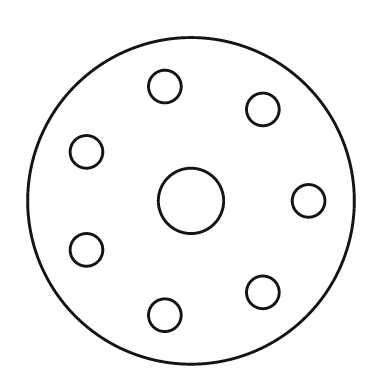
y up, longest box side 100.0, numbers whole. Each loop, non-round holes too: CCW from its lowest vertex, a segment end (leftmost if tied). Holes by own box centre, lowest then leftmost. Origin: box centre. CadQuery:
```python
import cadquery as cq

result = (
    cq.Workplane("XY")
    .moveTo(0.0, 0.0)
    .circle(50.0)
    .moveTo(-8.0, -35.0)
    .circle(5.0)
    .moveTo(22.0, -28.0)
    .circle(5.0)
    .moveTo(-32.0, -15.0)
    .circle(5.0)
    .moveTo(0.0, 0.0)
    .circle(10.0)
    .moveTo(36.0, 0.0)
    .circle(5.0)
    .moveTo(-32.0, 15.0)
    .circle(5.0)
    .moveTo(22.0, 28.0)
    .circle(5.0)
    .moveTo(-8.0, 35.0)
    .circle(5.0)
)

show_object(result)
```